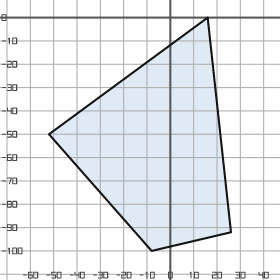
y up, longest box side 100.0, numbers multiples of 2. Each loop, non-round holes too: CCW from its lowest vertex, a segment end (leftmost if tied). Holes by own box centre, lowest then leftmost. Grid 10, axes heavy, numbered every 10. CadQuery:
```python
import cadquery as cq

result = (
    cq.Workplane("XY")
    .moveTo(-8.0, -100.0)
    .lineTo(26.0, -92.0)
    .lineTo(16.0, 0.0)
    .lineTo(-52.0, -50.0)
    .close()
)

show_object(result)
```